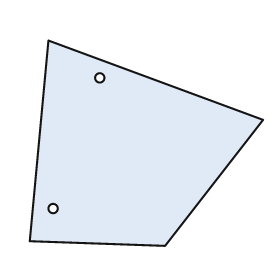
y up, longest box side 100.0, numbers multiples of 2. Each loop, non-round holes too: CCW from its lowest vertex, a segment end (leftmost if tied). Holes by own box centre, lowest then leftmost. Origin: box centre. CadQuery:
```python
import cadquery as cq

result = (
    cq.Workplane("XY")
    .moveTo(8.0, -44.0)
    .lineTo(50.0, 10.0)
    .lineTo(-42.0, 44.0)
    .lineTo(-50.0, -42.0)
    .close()
    .moveTo(-40.0, -28.0)
    .circle(2.0)
    .moveTo(-20.0, 28.0)
    .circle(2.0)
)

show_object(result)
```